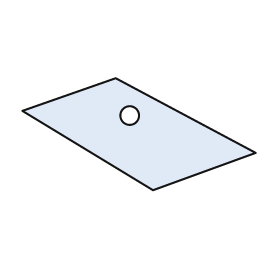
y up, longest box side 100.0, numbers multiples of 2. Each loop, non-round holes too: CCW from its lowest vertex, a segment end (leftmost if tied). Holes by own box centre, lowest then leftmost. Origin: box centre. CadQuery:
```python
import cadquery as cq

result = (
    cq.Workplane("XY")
    .moveTo(6.0, -24.0)
    .lineTo(50.0, -8.0)
    .lineTo(-10.0, 24.0)
    .lineTo(-50.0, 10.0)
    .close()
    .moveTo(-4.0, 8.0)
    .circle(4.0)
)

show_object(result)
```